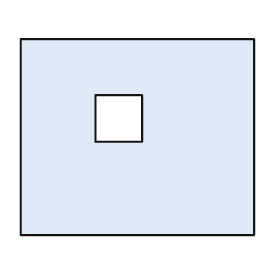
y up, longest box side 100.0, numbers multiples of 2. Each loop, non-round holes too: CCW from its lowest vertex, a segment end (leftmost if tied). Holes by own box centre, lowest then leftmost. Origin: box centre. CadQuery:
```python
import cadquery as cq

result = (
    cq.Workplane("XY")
    .moveTo(-50.0, -42.0)
    .lineTo(50.0, -42.0)
    .lineTo(50.0, 42.0)
    .lineTo(-50.0, 42.0)
    .close()
    .moveTo(-18.0, -2.0)
    .lineTo(2.0, -2.0)
    .lineTo(2.0, 18.0)
    .lineTo(-18.0, 18.0)
    .close()
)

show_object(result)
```